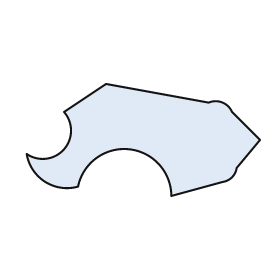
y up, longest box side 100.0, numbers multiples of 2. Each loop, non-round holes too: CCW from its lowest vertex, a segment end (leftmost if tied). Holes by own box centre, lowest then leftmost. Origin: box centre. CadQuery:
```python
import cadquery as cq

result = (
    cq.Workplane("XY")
    .moveTo(12.0, -24.0)
    .lineTo(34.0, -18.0)
    .threePointArc((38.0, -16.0), (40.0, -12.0))
    .lineTo(50.0, 0.0)
    .lineTo(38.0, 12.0)
    .threePointArc((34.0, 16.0), (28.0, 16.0))
    .lineTo(-16.0, 24.0)
    .lineTo(-34.0, 12.0)
    .threePointArc((-34.0, -4.0), (-50.0, -6.0))
    .threePointArc((-42.0, -18.0), (-28.0, -20.0))
    .threePointArc((-6.0, -4.0), (12.0, -24.0))
    .close()
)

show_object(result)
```